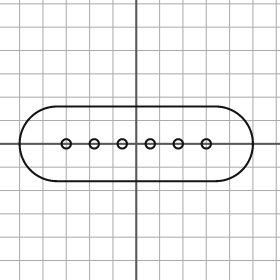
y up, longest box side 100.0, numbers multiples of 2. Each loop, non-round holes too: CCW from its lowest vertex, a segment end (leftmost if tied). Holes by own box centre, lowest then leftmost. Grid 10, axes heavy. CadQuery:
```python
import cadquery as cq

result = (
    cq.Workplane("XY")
    .moveTo(-34.0, -16.0)
    .lineTo(34.0, -16.0)
    .threePointArc((50.0, 0.0), (34.0, 16.0))
    .lineTo(-34.0, 16.0)
    .threePointArc((-50.0, 0.0), (-34.0, -16.0))
    .close()
    .moveTo(-30.0, 0.0)
    .circle(2.0)
    .moveTo(-18.0, 0.0)
    .circle(2.0)
    .moveTo(-6.0, 0.0)
    .circle(2.0)
    .moveTo(6.0, 0.0)
    .circle(2.0)
    .moveTo(18.0, 0.0)
    .circle(2.0)
    .moveTo(30.0, 0.0)
    .circle(2.0)
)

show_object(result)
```